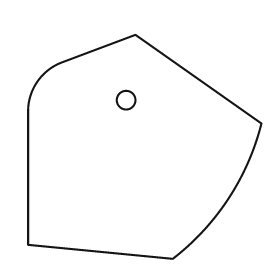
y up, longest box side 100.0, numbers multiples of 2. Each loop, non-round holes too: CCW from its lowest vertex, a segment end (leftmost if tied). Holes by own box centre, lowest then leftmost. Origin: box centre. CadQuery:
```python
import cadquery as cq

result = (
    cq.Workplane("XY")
    .moveTo(12.0, -48.0)
    .threePointArc((36.0, -22.0), (50.0, 10.0))
    .lineTo(-4.0, 48.0)
    .lineTo(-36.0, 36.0)
    .threePointArc((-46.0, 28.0), (-50.0, 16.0))
    .lineTo(-50.0, -42.0)
    .close()
    .moveTo(-8.0, 20.0)
    .circle(4.0)
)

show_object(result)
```